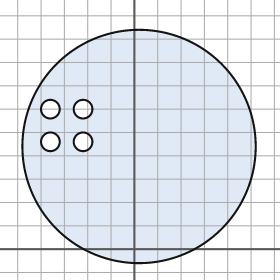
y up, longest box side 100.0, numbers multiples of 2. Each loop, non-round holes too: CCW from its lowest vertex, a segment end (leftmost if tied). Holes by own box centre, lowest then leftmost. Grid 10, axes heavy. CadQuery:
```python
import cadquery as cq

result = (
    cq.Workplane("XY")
    .moveTo(2.0, 44.0)
    .circle(50.0)
    .moveTo(-36.0, 46.0)
    .circle(4.0)
    .moveTo(-22.0, 46.0)
    .circle(4.0)
    .moveTo(-36.0, 60.0)
    .circle(4.0)
    .moveTo(-22.0, 60.0)
    .circle(4.0)
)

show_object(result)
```